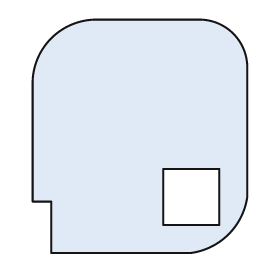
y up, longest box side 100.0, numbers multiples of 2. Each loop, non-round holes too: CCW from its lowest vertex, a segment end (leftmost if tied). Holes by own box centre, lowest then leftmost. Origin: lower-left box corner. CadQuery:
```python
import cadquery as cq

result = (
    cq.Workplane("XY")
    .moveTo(8.0, 0.0)
    .lineTo(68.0, 0.0)
    .threePointArc((84.0, 8.0), (92.0, 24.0))
    .lineTo(92.0, 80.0)
    .threePointArc((86.0, 94.0), (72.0, 100.0))
    .lineTo(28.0, 100.0)
    .threePointArc((8.0, 92.0), (0.0, 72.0))
    .lineTo(0.0, 22.0)
    .lineTo(8.0, 22.0)
    .close()
    .moveTo(56.0, 12.0)
    .lineTo(80.0, 12.0)
    .lineTo(80.0, 36.0)
    .lineTo(56.0, 36.0)
    .close()
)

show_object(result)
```